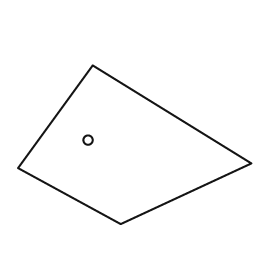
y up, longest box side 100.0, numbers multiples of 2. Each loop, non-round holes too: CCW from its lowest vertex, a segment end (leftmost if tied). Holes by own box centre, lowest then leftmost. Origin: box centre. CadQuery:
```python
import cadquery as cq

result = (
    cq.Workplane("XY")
    .moveTo(-6.0, -34.0)
    .lineTo(50.0, -8.0)
    .lineTo(-18.0, 34.0)
    .lineTo(-50.0, -10.0)
    .close()
    .moveTo(-20.0, 2.0)
    .circle(2.0)
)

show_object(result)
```